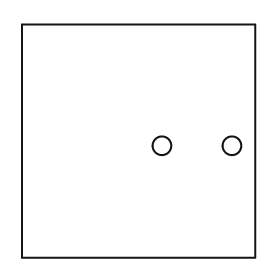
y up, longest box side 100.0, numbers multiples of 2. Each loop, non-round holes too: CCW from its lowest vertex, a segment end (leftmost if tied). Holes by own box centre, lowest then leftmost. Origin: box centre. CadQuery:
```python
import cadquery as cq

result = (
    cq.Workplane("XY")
    .moveTo(-50.0, -50.0)
    .lineTo(50.0, -50.0)
    .lineTo(50.0, 50.0)
    .lineTo(-50.0, 50.0)
    .close()
    .moveTo(10.0, -2.0)
    .circle(4.0)
    .moveTo(40.0, -2.0)
    .circle(4.0)
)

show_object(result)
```